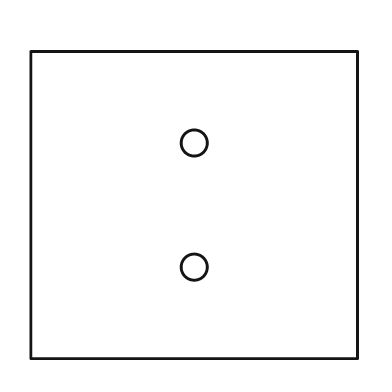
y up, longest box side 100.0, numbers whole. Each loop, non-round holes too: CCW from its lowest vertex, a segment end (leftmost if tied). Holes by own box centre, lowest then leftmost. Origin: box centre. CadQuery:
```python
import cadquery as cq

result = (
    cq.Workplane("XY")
    .moveTo(-50.0, -47.0)
    .lineTo(50.0, -47.0)
    .lineTo(50.0, 47.0)
    .lineTo(-50.0, 47.0)
    .close()
    .moveTo(0.0, -19.0)
    .circle(4.0)
    .moveTo(0.0, 19.0)
    .circle(4.0)
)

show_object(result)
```